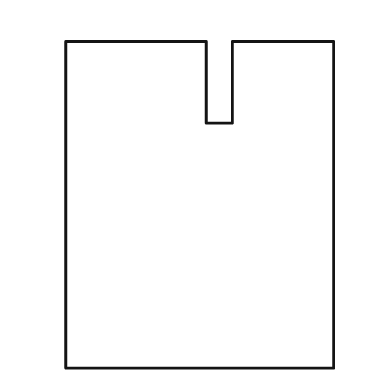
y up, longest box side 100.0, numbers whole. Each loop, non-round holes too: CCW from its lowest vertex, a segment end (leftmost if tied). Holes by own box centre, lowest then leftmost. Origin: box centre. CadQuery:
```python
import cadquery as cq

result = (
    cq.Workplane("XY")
    .moveTo(-41.0, -50.0)
    .lineTo(41.0, -50.0)
    .lineTo(41.0, 50.0)
    .lineTo(10.0, 50.0)
    .lineTo(10.0, 25.0)
    .lineTo(2.0, 25.0)
    .lineTo(2.0, 50.0)
    .lineTo(-41.0, 50.0)
    .close()
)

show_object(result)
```